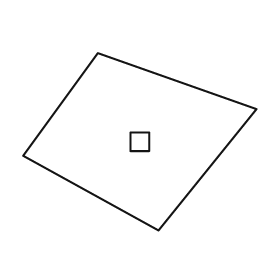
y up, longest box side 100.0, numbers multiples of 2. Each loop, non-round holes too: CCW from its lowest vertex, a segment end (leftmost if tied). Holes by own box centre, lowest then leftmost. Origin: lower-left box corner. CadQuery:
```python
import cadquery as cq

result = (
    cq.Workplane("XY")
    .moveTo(58.0, 0.0)
    .lineTo(100.0, 52.0)
    .lineTo(32.0, 76.0)
    .lineTo(0.0, 32.0)
    .close()
    .moveTo(46.0, 34.0)
    .lineTo(54.0, 34.0)
    .lineTo(54.0, 42.0)
    .lineTo(46.0, 42.0)
    .close()
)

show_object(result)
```